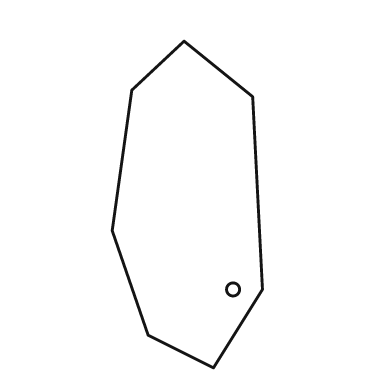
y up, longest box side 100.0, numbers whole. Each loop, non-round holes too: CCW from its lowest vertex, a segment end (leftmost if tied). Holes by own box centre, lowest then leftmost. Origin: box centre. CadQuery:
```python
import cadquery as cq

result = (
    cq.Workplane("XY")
    .moveTo(8.0, -50.0)
    .lineTo(23.0, -26.0)
    .lineTo(20.0, 33.0)
    .lineTo(-1.0, 50.0)
    .lineTo(-17.0, 35.0)
    .lineTo(-23.0, -8.0)
    .lineTo(-12.0, -40.0)
    .close()
    .moveTo(14.0, -26.0)
    .circle(2.0)
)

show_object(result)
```